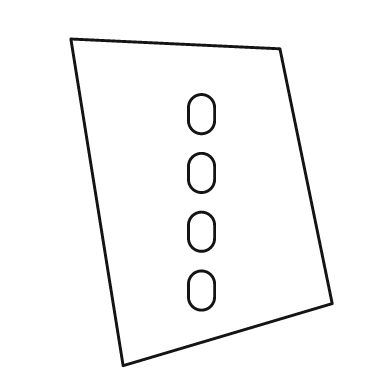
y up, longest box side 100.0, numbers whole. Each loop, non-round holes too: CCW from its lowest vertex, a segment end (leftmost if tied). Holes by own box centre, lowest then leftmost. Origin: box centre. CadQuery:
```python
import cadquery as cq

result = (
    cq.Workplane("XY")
    .moveTo(-24.0, -50.0)
    .lineTo(40.0, -31.0)
    .lineTo(24.0, 47.0)
    .lineTo(-40.0, 50.0)
    .close()
    .moveTo(-4.0, -29.0)
    .threePointArc((0.0, -33.0), (4.0, -29.0))
    .lineTo(4.0, -25.0)
    .threePointArc((0.0, -21.0), (-4.0, -25.0))
    .close()
    .moveTo(-4.0, -11.0)
    .threePointArc((0.0, -15.0), (4.0, -11.0))
    .lineTo(4.0, -7.0)
    .threePointArc((0.0, -3.0), (-4.0, -7.0))
    .close()
    .moveTo(-4.0, 7.0)
    .threePointArc((0.0, 3.0), (4.0, 7.0))
    .lineTo(4.0, 11.0)
    .threePointArc((0.0, 15.0), (-4.0, 11.0))
    .close()
    .moveTo(-4.0, 25.0)
    .threePointArc((0.0, 21.0), (4.0, 25.0))
    .lineTo(4.0, 29.0)
    .threePointArc((0.0, 33.0), (-4.0, 29.0))
    .close()
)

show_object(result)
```